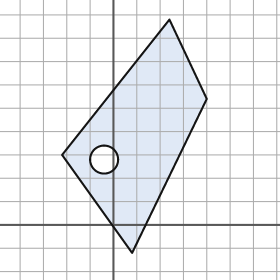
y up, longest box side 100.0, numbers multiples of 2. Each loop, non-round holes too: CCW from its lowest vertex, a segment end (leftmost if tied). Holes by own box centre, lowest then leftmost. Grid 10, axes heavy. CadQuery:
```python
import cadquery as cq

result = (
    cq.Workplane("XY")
    .moveTo(8.0, -12.0)
    .lineTo(40.0, 54.0)
    .lineTo(24.0, 88.0)
    .lineTo(-22.0, 30.0)
    .close()
    .moveTo(-4.0, 28.0)
    .circle(6.0)
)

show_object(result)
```